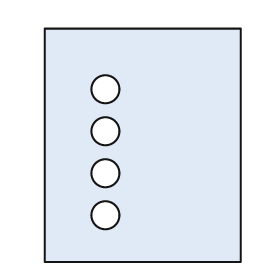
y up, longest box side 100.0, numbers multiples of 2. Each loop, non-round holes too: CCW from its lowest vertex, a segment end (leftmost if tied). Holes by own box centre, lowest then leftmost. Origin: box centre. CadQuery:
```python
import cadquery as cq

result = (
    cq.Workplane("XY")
    .moveTo(-42.0, -50.0)
    .lineTo(42.0, -50.0)
    .lineTo(42.0, 50.0)
    .lineTo(-42.0, 50.0)
    .close()
    .moveTo(-16.0, -30.0)
    .circle(6.0)
    .moveTo(-16.0, -12.0)
    .circle(6.0)
    .moveTo(-16.0, 6.0)
    .circle(6.0)
    .moveTo(-16.0, 24.0)
    .circle(6.0)
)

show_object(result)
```